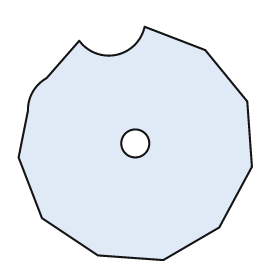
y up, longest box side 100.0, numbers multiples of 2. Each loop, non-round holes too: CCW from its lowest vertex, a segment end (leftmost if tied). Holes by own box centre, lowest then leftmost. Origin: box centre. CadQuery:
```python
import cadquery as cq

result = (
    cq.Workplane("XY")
    .moveTo(12.0, -50.0)
    .lineTo(36.0, -36.0)
    .lineTo(50.0, -10.0)
    .lineTo(48.0, 18.0)
    .lineTo(30.0, 40.0)
    .lineTo(4.0, 50.0)
    .threePointArc((-8.0, 38.0), (-24.0, 44.0))
    .lineTo(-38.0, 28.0)
    .threePointArc((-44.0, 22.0), (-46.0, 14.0))
    .lineTo(-50.0, -6.0)
    .lineTo(-40.0, -32.0)
    .lineTo(-16.0, -48.0)
    .close()
    .moveTo(0.0, 0.0)
    .circle(6.0)
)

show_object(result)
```